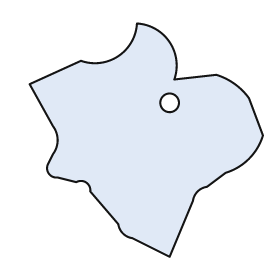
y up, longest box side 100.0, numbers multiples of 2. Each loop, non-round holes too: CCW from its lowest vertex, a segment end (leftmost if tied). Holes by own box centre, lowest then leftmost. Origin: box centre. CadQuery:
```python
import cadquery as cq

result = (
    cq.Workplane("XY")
    .moveTo(10.0, -50.0)
    .lineTo(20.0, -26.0)
    .threePointArc((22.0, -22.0), (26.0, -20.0))
    .lineTo(34.0, -14.0)
    .threePointArc((44.0, -8.0), (50.0, 2.0))
    .lineTo(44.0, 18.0)
    .threePointArc((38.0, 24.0), (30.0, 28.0))
    .lineTo(12.0, 26.0)
    .threePointArc((10.0, 42.0), (-4.0, 50.0))
    .threePointArc((-12.0, 36.0), (-28.0, 34.0))
    .lineTo(-50.0, 24.0)
    .lineTo(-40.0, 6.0)
    .threePointArc((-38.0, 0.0), (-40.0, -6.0))
    .lineTo(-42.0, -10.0)
    .threePointArc((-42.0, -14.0), (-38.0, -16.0))
    .lineTo(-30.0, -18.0)
    .threePointArc((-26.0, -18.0), (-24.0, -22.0))
    .lineTo(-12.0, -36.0)
    .threePointArc((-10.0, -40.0), (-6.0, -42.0))
    .close()
    .moveTo(10.0, 16.0)
    .circle(4.0)
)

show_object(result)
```